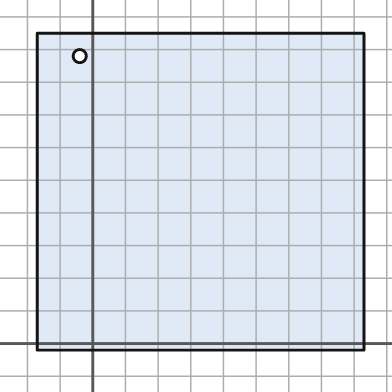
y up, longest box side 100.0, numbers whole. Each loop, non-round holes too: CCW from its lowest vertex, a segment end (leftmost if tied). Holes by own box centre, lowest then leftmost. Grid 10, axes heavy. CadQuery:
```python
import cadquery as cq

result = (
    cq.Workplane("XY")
    .moveTo(-17.0, -2.0)
    .lineTo(83.0, -2.0)
    .lineTo(83.0, 95.0)
    .lineTo(-17.0, 95.0)
    .close()
    .moveTo(-4.0, 88.0)
    .circle(2.0)
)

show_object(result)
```